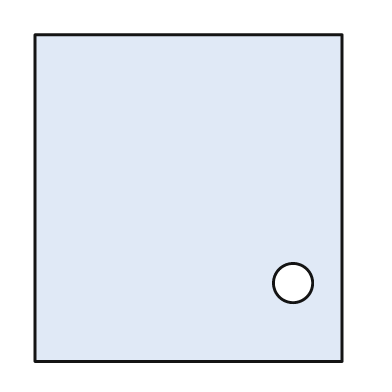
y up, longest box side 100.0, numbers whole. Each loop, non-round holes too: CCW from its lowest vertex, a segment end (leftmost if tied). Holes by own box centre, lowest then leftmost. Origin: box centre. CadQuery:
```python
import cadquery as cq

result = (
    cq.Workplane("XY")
    .moveTo(-47.0, -50.0)
    .lineTo(47.0, -50.0)
    .lineTo(47.0, 50.0)
    .lineTo(-47.0, 50.0)
    .close()
    .moveTo(32.0, -26.0)
    .circle(6.0)
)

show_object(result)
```